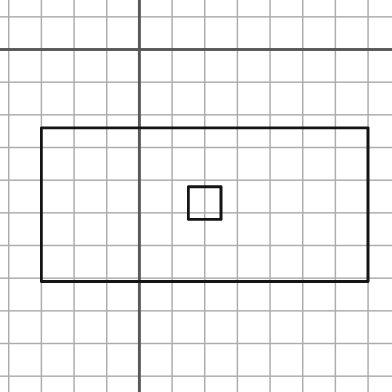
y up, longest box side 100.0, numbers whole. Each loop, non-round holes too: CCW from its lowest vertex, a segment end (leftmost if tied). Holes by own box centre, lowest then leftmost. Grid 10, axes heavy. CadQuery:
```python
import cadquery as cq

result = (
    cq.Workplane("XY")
    .moveTo(-30.0, -71.0)
    .lineTo(70.0, -71.0)
    .lineTo(70.0, -24.0)
    .lineTo(-30.0, -24.0)
    .close()
    .moveTo(15.0, -52.0)
    .lineTo(25.0, -52.0)
    .lineTo(25.0, -42.0)
    .lineTo(15.0, -42.0)
    .close()
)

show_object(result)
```